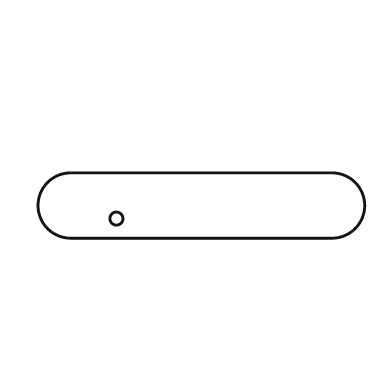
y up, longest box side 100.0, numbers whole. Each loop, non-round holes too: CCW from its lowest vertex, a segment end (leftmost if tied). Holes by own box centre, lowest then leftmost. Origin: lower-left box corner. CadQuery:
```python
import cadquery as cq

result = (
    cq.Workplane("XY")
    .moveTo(10.0, 0.0)
    .lineTo(90.0, 0.0)
    .threePointArc((100.0, 10.0), (90.0, 20.0))
    .lineTo(10.0, 20.0)
    .threePointArc((0.0, 10.0), (10.0, 0.0))
    .close()
    .moveTo(24.0, 6.0)
    .circle(2.0)
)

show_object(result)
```